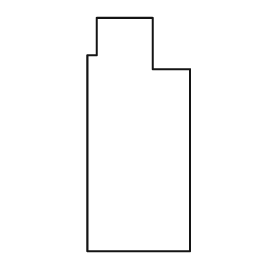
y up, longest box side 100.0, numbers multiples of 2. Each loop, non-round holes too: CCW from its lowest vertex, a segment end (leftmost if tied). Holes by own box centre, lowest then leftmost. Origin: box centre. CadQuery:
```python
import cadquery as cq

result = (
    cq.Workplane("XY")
    .moveTo(-22.0, -50.0)
    .lineTo(22.0, -50.0)
    .lineTo(22.0, 28.0)
    .lineTo(6.0, 28.0)
    .lineTo(6.0, 50.0)
    .lineTo(-18.0, 50.0)
    .lineTo(-18.0, 34.0)
    .lineTo(-22.0, 34.0)
    .close()
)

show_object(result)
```